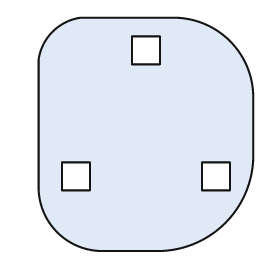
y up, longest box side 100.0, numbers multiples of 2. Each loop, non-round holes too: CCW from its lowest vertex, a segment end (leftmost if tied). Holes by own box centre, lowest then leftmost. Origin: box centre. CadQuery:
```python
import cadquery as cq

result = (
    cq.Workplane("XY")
    .moveTo(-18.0, -50.0)
    .lineTo(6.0, -50.0)
    .threePointArc((34.0, -38.0), (46.0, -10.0))
    .lineTo(46.0, 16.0)
    .threePointArc((36.0, 40.0), (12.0, 50.0))
    .lineTo(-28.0, 50.0)
    .threePointArc((-40.0, 44.0), (-46.0, 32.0))
    .lineTo(-46.0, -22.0)
    .threePointArc((-38.0, -42.0), (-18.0, -50.0))
    .close()
    .moveTo(-36.0, -24.0)
    .lineTo(-24.0, -24.0)
    .lineTo(-24.0, -12.0)
    .lineTo(-36.0, -12.0)
    .close()
    .moveTo(24.0, -24.0)
    .lineTo(36.0, -24.0)
    .lineTo(36.0, -12.0)
    .lineTo(24.0, -12.0)
    .close()
    .moveTo(-6.0, 30.0)
    .lineTo(6.0, 30.0)
    .lineTo(6.0, 42.0)
    .lineTo(-6.0, 42.0)
    .close()
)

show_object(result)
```